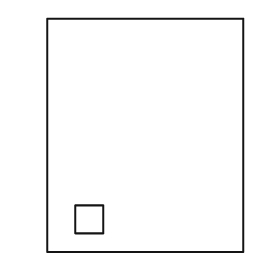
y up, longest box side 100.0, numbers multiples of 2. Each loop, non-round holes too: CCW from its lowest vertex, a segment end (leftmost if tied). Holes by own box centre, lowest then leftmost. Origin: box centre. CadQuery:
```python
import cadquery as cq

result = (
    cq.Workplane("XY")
    .moveTo(-42.0, -50.0)
    .lineTo(42.0, -50.0)
    .lineTo(42.0, 50.0)
    .lineTo(-42.0, 50.0)
    .close()
    .moveTo(-30.0, -42.0)
    .lineTo(-18.0, -42.0)
    .lineTo(-18.0, -30.0)
    .lineTo(-30.0, -30.0)
    .close()
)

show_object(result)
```